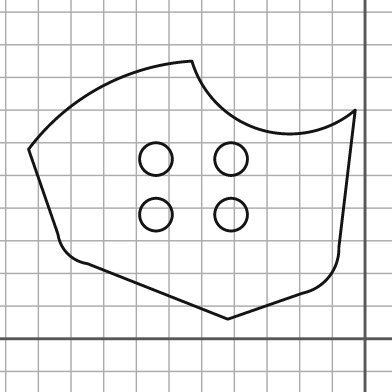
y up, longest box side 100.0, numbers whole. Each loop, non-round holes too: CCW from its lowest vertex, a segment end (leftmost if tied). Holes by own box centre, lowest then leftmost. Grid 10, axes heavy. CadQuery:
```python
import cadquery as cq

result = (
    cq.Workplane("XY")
    .moveTo(-42.0, 6.0)
    .lineTo(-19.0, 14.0)
    .threePointArc((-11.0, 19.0), (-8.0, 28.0))
    .lineTo(-3.0, 70.0)
    .threePointArc((-32.0, 64.0), (-53.0, 85.0))
    .threePointArc((-81.0, 77.0), (-103.0, 58.0))
    .lineTo(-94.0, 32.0)
    .threePointArc((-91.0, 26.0), (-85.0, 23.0))
    .close()
    .moveTo(-64.0, 38.0)
    .circle(5.0)
    .moveTo(-41.0, 38.0)
    .circle(5.0)
    .moveTo(-64.0, 55.0)
    .circle(5.0)
    .moveTo(-41.0, 55.0)
    .circle(5.0)
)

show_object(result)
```